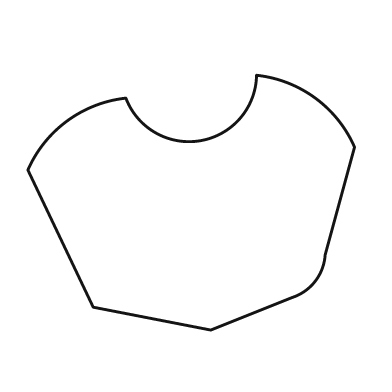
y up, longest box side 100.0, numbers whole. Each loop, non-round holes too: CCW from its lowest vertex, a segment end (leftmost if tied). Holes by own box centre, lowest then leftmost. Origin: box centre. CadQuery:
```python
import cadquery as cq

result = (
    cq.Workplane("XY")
    .moveTo(6.0, -39.0)
    .lineTo(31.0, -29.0)
    .threePointArc((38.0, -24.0), (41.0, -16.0))
    .lineTo(50.0, 17.0)
    .threePointArc((38.0, 32.0), (20.0, 39.0))
    .threePointArc((3.0, 19.0), (-20.0, 32.0))
    .threePointArc((-38.0, 25.0), (-50.0, 10.0))
    .lineTo(-30.0, -32.0)
    .close()
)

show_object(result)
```